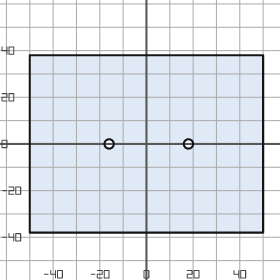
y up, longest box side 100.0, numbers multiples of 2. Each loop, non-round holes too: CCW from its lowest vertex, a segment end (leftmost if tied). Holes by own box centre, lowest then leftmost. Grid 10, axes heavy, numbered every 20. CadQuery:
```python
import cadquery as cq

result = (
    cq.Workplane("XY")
    .moveTo(-50.0, -38.0)
    .lineTo(50.0, -38.0)
    .lineTo(50.0, 38.0)
    .lineTo(-50.0, 38.0)
    .close()
    .moveTo(-16.0, 0.0)
    .circle(2.0)
    .moveTo(18.0, 0.0)
    .circle(2.0)
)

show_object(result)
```